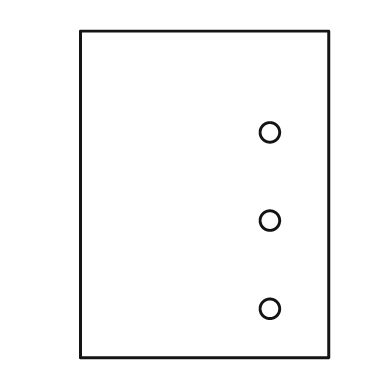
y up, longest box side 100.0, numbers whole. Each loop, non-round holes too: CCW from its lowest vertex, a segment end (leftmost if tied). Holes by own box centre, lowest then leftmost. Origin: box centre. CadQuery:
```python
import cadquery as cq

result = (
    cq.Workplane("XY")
    .moveTo(-38.0, -50.0)
    .lineTo(38.0, -50.0)
    .lineTo(38.0, 50.0)
    .lineTo(-38.0, 50.0)
    .close()
    .moveTo(20.0, -35.0)
    .circle(3.0)
    .moveTo(20.0, -8.0)
    .circle(3.0)
    .moveTo(20.0, 19.0)
    .circle(3.0)
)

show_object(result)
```